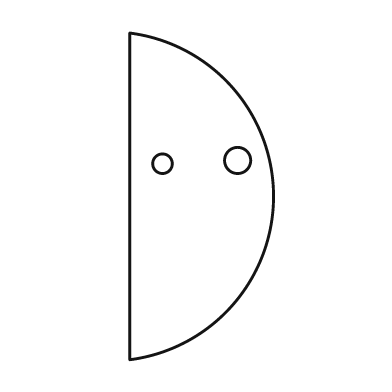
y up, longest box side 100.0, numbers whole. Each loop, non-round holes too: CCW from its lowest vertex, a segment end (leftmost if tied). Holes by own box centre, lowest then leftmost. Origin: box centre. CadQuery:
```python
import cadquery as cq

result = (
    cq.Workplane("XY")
    .moveTo(-22.0, -50.0)
    .threePointArc((22.0, 0.0), (-22.0, 50.0))
    .close()
    .moveTo(-12.0, 10.0)
    .circle(3.0)
    .moveTo(11.0, 11.0)
    .circle(4.0)
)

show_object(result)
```